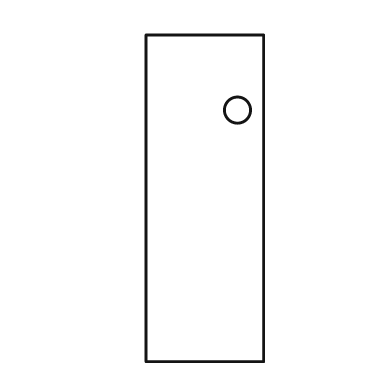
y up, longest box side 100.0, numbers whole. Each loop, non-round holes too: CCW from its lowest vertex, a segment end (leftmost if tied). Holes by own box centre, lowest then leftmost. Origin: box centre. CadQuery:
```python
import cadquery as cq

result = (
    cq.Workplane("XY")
    .moveTo(-18.0, -50.0)
    .lineTo(18.0, -50.0)
    .lineTo(18.0, 50.0)
    .lineTo(-18.0, 50.0)
    .close()
    .moveTo(10.0, 27.0)
    .circle(4.0)
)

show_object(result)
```